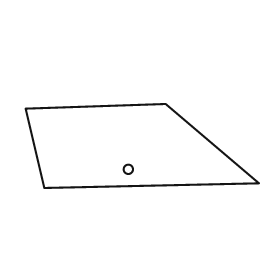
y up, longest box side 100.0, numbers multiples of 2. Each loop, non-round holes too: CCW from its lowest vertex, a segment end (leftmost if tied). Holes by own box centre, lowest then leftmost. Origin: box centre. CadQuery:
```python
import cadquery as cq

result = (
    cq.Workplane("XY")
    .moveTo(-42.0, -18.0)
    .lineTo(50.0, -16.0)
    .lineTo(10.0, 18.0)
    .lineTo(-50.0, 16.0)
    .close()
    .moveTo(-6.0, -10.0)
    .circle(2.0)
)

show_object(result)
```